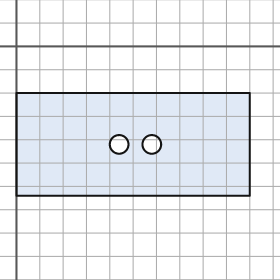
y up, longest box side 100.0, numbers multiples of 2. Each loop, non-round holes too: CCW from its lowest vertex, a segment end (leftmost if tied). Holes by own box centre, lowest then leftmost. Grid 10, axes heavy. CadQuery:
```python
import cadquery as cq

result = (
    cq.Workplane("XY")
    .moveTo(0.0, -64.0)
    .lineTo(100.0, -64.0)
    .lineTo(100.0, -20.0)
    .lineTo(0.0, -20.0)
    .close()
    .moveTo(44.0, -42.0)
    .circle(4.0)
    .moveTo(58.0, -42.0)
    .circle(4.0)
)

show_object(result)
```